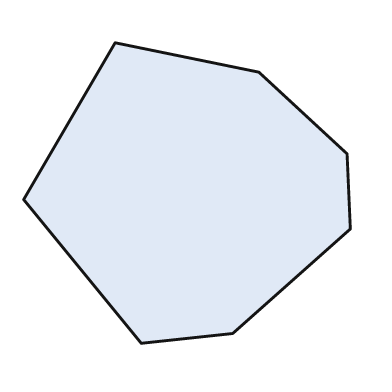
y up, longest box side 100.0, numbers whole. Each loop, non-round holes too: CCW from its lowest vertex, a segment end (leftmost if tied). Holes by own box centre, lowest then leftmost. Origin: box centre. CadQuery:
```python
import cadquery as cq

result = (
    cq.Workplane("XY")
    .moveTo(-14.0, -46.0)
    .lineTo(14.0, -43.0)
    .lineTo(50.0, -11.0)
    .lineTo(49.0, 12.0)
    .lineTo(22.0, 37.0)
    .lineTo(-22.0, 46.0)
    .lineTo(-50.0, -2.0)
    .close()
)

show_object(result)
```